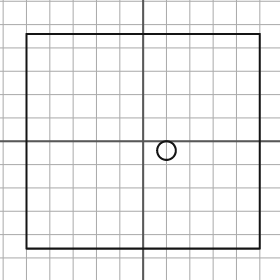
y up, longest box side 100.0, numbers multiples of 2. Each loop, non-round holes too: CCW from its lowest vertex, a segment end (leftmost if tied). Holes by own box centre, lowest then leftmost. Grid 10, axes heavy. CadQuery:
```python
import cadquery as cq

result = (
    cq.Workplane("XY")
    .moveTo(-50.0, -46.0)
    .lineTo(50.0, -46.0)
    .lineTo(50.0, 46.0)
    .lineTo(-50.0, 46.0)
    .close()
    .moveTo(10.0, -4.0)
    .circle(4.0)
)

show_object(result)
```